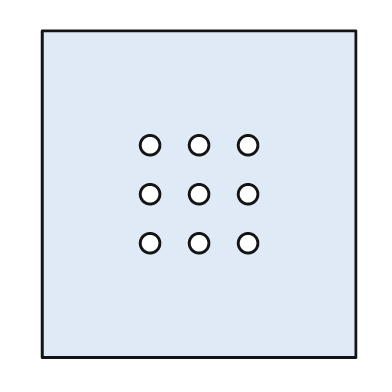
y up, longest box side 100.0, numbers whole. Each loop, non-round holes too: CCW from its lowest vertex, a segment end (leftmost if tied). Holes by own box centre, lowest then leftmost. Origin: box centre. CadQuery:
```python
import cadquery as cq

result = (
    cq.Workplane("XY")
    .moveTo(-48.0, -50.0)
    .lineTo(48.0, -50.0)
    .lineTo(48.0, 50.0)
    .lineTo(-48.0, 50.0)
    .close()
    .moveTo(-15.0, -15.0)
    .circle(3.0)
    .moveTo(0.0, -15.0)
    .circle(3.0)
    .moveTo(15.0, -15.0)
    .circle(3.0)
    .moveTo(-15.0, 0.0)
    .circle(3.0)
    .moveTo(0.0, 0.0)
    .circle(3.0)
    .moveTo(15.0, 0.0)
    .circle(3.0)
    .moveTo(-15.0, 15.0)
    .circle(3.0)
    .moveTo(0.0, 15.0)
    .circle(3.0)
    .moveTo(15.0, 15.0)
    .circle(3.0)
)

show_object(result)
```